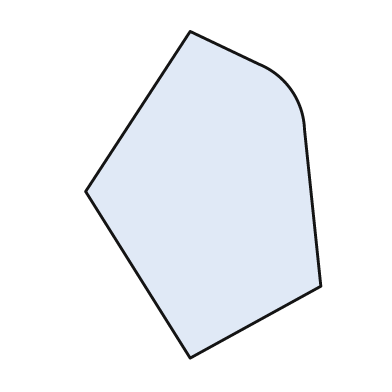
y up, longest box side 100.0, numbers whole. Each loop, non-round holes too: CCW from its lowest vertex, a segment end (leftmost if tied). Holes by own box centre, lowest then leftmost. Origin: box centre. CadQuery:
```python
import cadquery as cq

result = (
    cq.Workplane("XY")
    .moveTo(-4.0, -50.0)
    .lineTo(36.0, -28.0)
    .lineTo(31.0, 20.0)
    .threePointArc((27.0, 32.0), (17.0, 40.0))
    .lineTo(-4.0, 50.0)
    .lineTo(-36.0, 1.0)
    .close()
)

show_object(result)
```